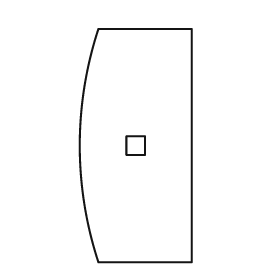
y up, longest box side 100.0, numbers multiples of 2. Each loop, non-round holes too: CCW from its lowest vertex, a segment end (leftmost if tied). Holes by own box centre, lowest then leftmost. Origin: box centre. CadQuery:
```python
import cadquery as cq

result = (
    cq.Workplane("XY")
    .moveTo(-16.0, -50.0)
    .lineTo(24.0, -50.0)
    .lineTo(24.0, 50.0)
    .lineTo(-16.0, 50.0)
    .threePointArc((-24.0, 0.0), (-16.0, -50.0))
    .close()
    .moveTo(-4.0, -4.0)
    .lineTo(4.0, -4.0)
    .lineTo(4.0, 4.0)
    .lineTo(-4.0, 4.0)
    .close()
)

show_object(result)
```